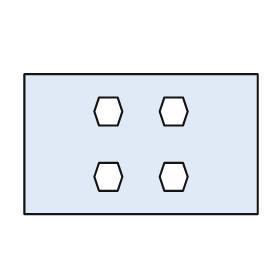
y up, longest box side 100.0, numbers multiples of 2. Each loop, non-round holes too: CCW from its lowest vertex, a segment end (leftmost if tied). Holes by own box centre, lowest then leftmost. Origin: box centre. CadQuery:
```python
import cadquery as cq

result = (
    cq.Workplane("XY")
    .moveTo(-50.0, -30.0)
    .lineTo(50.0, -30.0)
    .lineTo(50.0, 30.0)
    .lineTo(-50.0, 30.0)
    .close()
    .moveTo(-18.0, -20.0)
    .lineTo(-10.0, -20.0)
    .lineTo(-8.0, -14.0)
    .lineTo(-10.0, -8.0)
    .lineTo(-18.0, -8.0)
    .lineTo(-20.0, -14.0)
    .close()
    .moveTo(10.0, -20.0)
    .lineTo(18.0, -20.0)
    .lineTo(20.0, -14.0)
    .lineTo(18.0, -8.0)
    .lineTo(10.0, -8.0)
    .lineTo(8.0, -14.0)
    .close()
    .moveTo(-18.0, 8.0)
    .lineTo(-10.0, 8.0)
    .lineTo(-8.0, 14.0)
    .lineTo(-10.0, 20.0)
    .lineTo(-18.0, 20.0)
    .lineTo(-20.0, 14.0)
    .close()
    .moveTo(10.0, 8.0)
    .lineTo(18.0, 8.0)
    .lineTo(20.0, 14.0)
    .lineTo(18.0, 20.0)
    .lineTo(10.0, 20.0)
    .lineTo(8.0, 14.0)
    .close()
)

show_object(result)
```